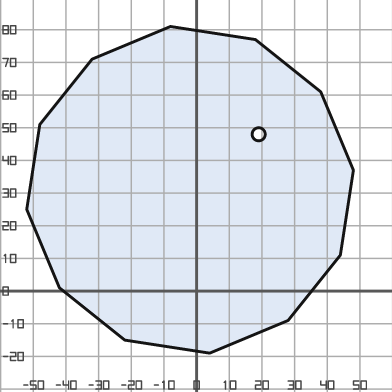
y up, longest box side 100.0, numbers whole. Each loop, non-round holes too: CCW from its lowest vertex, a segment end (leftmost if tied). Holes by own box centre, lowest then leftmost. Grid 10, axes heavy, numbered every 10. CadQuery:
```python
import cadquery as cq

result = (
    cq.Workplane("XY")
    .moveTo(4.0, -19.0)
    .lineTo(28.0, -9.0)
    .lineTo(44.0, 11.0)
    .lineTo(48.0, 37.0)
    .lineTo(38.0, 61.0)
    .lineTo(18.0, 77.0)
    .lineTo(-8.0, 81.0)
    .lineTo(-32.0, 71.0)
    .lineTo(-48.0, 51.0)
    .lineTo(-52.0, 25.0)
    .lineTo(-42.0, 1.0)
    .lineTo(-22.0, -15.0)
    .close()
    .moveTo(19.0, 48.0)
    .circle(2.0)
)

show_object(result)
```